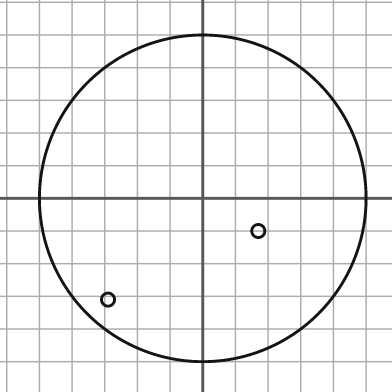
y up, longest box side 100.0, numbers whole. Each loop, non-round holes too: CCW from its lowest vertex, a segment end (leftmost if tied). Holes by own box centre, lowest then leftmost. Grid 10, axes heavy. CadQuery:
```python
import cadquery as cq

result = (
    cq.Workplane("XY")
    .moveTo(0.0, 0.0)
    .circle(50.0)
    .moveTo(-29.0, -31.0)
    .circle(2.0)
    .moveTo(17.0, -10.0)
    .circle(2.0)
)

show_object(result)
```